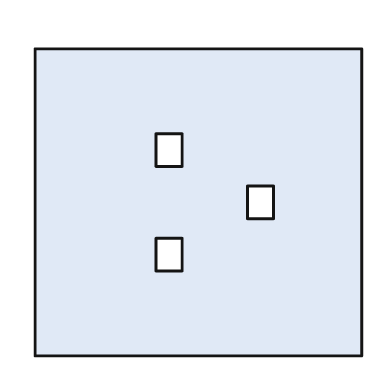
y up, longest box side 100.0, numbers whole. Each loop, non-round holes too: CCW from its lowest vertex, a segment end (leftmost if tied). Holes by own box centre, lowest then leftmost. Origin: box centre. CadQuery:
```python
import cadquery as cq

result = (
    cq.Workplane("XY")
    .moveTo(-50.0, -47.0)
    .lineTo(50.0, -47.0)
    .lineTo(50.0, 47.0)
    .lineTo(-50.0, 47.0)
    .close()
    .moveTo(-13.0, -21.0)
    .lineTo(-5.0, -21.0)
    .lineTo(-5.0, -11.0)
    .lineTo(-13.0, -11.0)
    .close()
    .moveTo(15.0, -5.0)
    .lineTo(23.0, -5.0)
    .lineTo(23.0, 5.0)
    .lineTo(15.0, 5.0)
    .close()
    .moveTo(-13.0, 11.0)
    .lineTo(-5.0, 11.0)
    .lineTo(-5.0, 21.0)
    .lineTo(-13.0, 21.0)
    .close()
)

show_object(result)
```